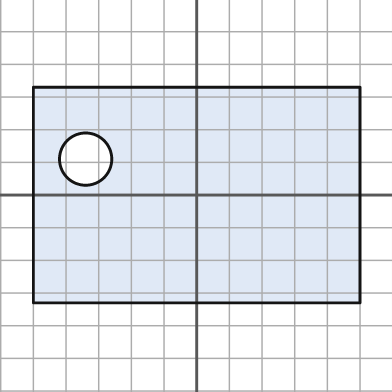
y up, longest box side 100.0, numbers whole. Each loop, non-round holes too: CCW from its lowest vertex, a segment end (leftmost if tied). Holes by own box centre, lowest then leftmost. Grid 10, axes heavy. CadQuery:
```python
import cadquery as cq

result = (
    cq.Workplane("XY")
    .moveTo(-50.0, -33.0)
    .lineTo(50.0, -33.0)
    .lineTo(50.0, 33.0)
    .lineTo(-50.0, 33.0)
    .close()
    .moveTo(-34.0, 11.0)
    .circle(8.0)
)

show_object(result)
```